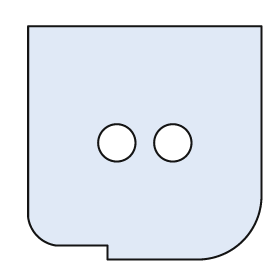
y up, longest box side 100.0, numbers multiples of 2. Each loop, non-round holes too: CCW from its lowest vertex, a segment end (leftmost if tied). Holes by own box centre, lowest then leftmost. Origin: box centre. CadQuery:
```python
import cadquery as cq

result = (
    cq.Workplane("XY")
    .moveTo(-16.0, -50.0)
    .lineTo(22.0, -50.0)
    .threePointArc((42.0, -42.0), (50.0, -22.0))
    .lineTo(50.0, 50.0)
    .lineTo(-50.0, 50.0)
    .lineTo(-50.0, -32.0)
    .threePointArc((-46.0, -40.0), (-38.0, -44.0))
    .lineTo(-16.0, -44.0)
    .close()
    .moveTo(-12.0, 0.0)
    .circle(8.0)
    .moveTo(12.0, 0.0)
    .circle(8.0)
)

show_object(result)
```